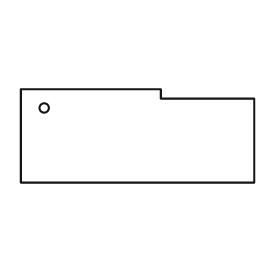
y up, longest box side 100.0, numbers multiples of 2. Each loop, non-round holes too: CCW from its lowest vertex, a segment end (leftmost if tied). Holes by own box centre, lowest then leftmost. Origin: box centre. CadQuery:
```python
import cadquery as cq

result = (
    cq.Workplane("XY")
    .moveTo(-50.0, -20.0)
    .lineTo(50.0, -20.0)
    .lineTo(50.0, 16.0)
    .lineTo(10.0, 16.0)
    .lineTo(10.0, 20.0)
    .lineTo(-50.0, 20.0)
    .close()
    .moveTo(-40.0, 12.0)
    .circle(2.0)
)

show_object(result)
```